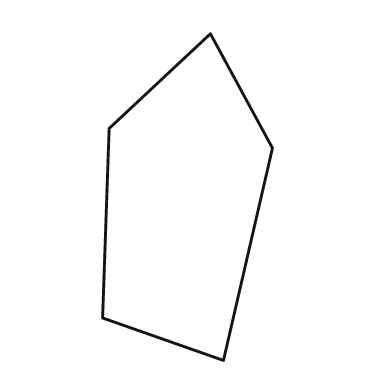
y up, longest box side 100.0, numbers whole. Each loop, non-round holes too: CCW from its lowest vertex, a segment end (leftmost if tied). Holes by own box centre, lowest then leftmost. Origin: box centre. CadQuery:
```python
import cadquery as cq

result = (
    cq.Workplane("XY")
    .moveTo(11.0, -50.0)
    .lineTo(26.0, 15.0)
    .lineTo(7.0, 50.0)
    .lineTo(-24.0, 21.0)
    .lineTo(-26.0, -37.0)
    .close()
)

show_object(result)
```